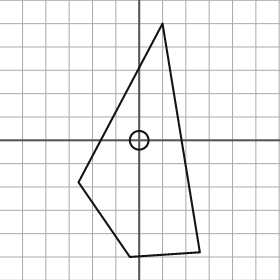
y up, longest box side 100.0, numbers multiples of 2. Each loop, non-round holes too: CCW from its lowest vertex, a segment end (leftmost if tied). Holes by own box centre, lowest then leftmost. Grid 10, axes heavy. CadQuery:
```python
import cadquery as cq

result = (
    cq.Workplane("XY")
    .moveTo(-4.0, -50.0)
    .lineTo(26.0, -48.0)
    .lineTo(10.0, 50.0)
    .lineTo(-26.0, -18.0)
    .close()
    .moveTo(0.0, 0.0)
    .circle(4.0)
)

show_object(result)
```